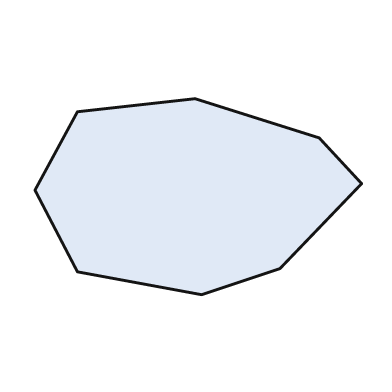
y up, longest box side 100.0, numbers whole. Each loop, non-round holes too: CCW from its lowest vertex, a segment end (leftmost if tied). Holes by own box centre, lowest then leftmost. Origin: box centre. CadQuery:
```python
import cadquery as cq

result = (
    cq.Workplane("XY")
    .moveTo(1.0, -30.0)
    .lineTo(25.0, -22.0)
    .lineTo(50.0, 4.0)
    .lineTo(37.0, 18.0)
    .lineTo(-1.0, 30.0)
    .lineTo(-37.0, 26.0)
    .lineTo(-50.0, 2.0)
    .lineTo(-37.0, -23.0)
    .close()
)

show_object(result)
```